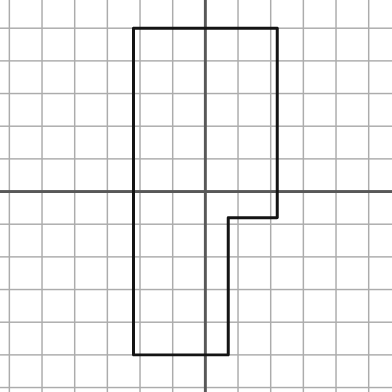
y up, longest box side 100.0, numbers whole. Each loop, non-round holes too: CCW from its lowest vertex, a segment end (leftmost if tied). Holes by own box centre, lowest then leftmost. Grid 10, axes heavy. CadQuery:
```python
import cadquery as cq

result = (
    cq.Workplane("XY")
    .moveTo(-22.0, -50.0)
    .lineTo(7.0, -50.0)
    .lineTo(7.0, -8.0)
    .lineTo(22.0, -8.0)
    .lineTo(22.0, 50.0)
    .lineTo(-22.0, 50.0)
    .close()
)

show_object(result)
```